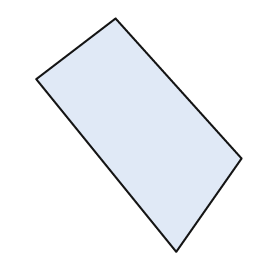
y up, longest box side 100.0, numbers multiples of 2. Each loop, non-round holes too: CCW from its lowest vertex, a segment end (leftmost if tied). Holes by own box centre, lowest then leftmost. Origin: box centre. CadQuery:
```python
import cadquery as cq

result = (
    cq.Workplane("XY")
    .moveTo(16.0, -50.0)
    .lineTo(44.0, -10.0)
    .lineTo(-10.0, 50.0)
    .lineTo(-44.0, 24.0)
    .close()
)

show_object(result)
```